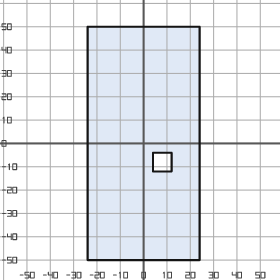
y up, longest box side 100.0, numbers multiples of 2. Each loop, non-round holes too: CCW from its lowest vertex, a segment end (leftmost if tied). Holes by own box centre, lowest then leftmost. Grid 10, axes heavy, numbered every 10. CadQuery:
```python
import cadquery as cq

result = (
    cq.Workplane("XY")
    .moveTo(-24.0, -50.0)
    .lineTo(24.0, -50.0)
    .lineTo(24.0, 50.0)
    .lineTo(-24.0, 50.0)
    .close()
    .moveTo(4.0, -12.0)
    .lineTo(12.0, -12.0)
    .lineTo(12.0, -4.0)
    .lineTo(4.0, -4.0)
    .close()
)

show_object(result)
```